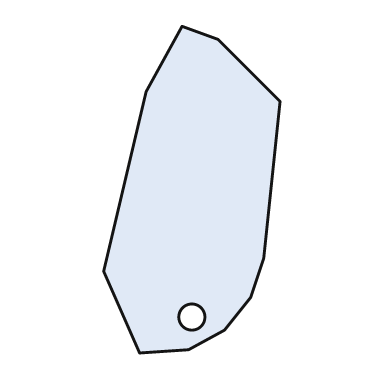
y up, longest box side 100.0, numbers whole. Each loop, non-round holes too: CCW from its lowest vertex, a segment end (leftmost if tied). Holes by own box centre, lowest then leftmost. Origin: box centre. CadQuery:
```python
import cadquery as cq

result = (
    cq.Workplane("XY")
    .moveTo(-16.0, -50.0)
    .lineTo(-1.0, -49.0)
    .lineTo(10.0, -43.0)
    .lineTo(18.0, -33.0)
    .lineTo(22.0, -21.0)
    .lineTo(27.0, 27.0)
    .lineTo(8.0, 46.0)
    .lineTo(-3.0, 50.0)
    .lineTo(-14.0, 30.0)
    .lineTo(-27.0, -25.0)
    .close()
    .moveTo(0.0, -39.0)
    .circle(4.0)
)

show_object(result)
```